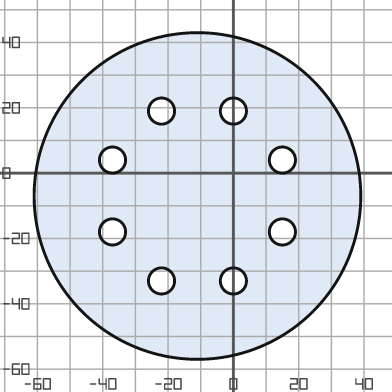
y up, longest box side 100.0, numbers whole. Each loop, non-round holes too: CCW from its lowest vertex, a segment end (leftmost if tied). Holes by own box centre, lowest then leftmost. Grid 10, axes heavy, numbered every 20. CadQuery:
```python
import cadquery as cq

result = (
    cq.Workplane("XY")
    .moveTo(-11.0, -7.0)
    .circle(50.0)
    .moveTo(-22.0, -33.0)
    .circle(4.0)
    .moveTo(0.0, -33.0)
    .circle(4.0)
    .moveTo(-37.0, -18.0)
    .circle(4.0)
    .moveTo(15.0, -18.0)
    .circle(4.0)
    .moveTo(-37.0, 4.0)
    .circle(4.0)
    .moveTo(15.0, 4.0)
    .circle(4.0)
    .moveTo(-22.0, 19.0)
    .circle(4.0)
    .moveTo(0.0, 19.0)
    .circle(4.0)
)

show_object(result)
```